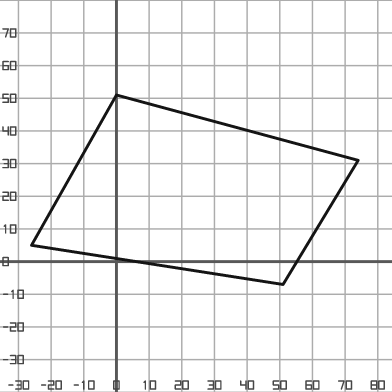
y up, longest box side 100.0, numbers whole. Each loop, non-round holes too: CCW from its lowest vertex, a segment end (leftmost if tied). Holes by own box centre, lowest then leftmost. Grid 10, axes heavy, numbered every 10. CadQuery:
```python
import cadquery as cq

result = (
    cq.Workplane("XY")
    .moveTo(51.0, -7.0)
    .lineTo(74.0, 31.0)
    .lineTo(0.0, 51.0)
    .lineTo(-26.0, 5.0)
    .close()
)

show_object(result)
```